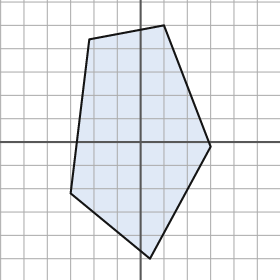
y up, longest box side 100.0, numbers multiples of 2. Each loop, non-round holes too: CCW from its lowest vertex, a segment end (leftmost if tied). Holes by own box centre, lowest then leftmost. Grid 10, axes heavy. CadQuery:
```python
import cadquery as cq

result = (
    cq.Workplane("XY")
    .moveTo(4.0, -50.0)
    .lineTo(30.0, -2.0)
    .lineTo(10.0, 50.0)
    .lineTo(-22.0, 44.0)
    .lineTo(-30.0, -22.0)
    .close()
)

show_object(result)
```